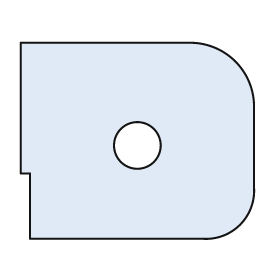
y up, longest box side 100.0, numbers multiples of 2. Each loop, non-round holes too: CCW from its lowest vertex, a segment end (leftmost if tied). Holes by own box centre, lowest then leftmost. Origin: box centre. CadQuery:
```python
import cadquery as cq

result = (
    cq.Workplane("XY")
    .moveTo(-46.0, -42.0)
    .lineTo(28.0, -42.0)
    .threePointArc((44.0, -36.0), (50.0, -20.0))
    .lineTo(50.0, 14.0)
    .threePointArc((42.0, 34.0), (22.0, 42.0))
    .lineTo(-50.0, 42.0)
    .lineTo(-50.0, -14.0)
    .lineTo(-46.0, -14.0)
    .close()
    .moveTo(0.0, -2.0)
    .circle(10.0)
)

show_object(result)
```